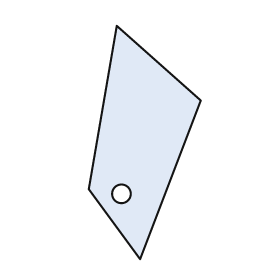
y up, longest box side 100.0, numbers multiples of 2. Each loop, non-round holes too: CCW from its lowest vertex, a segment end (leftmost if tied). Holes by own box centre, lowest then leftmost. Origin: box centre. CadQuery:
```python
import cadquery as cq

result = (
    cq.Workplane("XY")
    .moveTo(-2.0, -50.0)
    .lineTo(24.0, 18.0)
    .lineTo(-12.0, 50.0)
    .lineTo(-24.0, -20.0)
    .close()
    .moveTo(-10.0, -22.0)
    .circle(4.0)
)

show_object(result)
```